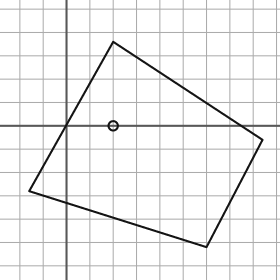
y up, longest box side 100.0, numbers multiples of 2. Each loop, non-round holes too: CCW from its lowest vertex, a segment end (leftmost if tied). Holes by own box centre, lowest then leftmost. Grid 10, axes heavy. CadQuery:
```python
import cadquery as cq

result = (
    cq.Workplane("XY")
    .moveTo(60.0, -52.0)
    .lineTo(84.0, -6.0)
    .lineTo(20.0, 36.0)
    .lineTo(-16.0, -28.0)
    .close()
    .moveTo(20.0, 0.0)
    .circle(2.0)
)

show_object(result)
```